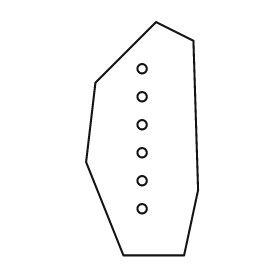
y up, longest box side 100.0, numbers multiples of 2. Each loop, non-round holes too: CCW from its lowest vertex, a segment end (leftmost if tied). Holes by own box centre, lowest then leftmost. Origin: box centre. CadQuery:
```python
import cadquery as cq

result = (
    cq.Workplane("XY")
    .moveTo(-8.0, -50.0)
    .lineTo(18.0, -50.0)
    .lineTo(24.0, -22.0)
    .lineTo(22.0, 42.0)
    .lineTo(6.0, 50.0)
    .lineTo(-20.0, 24.0)
    .lineTo(-24.0, -10.0)
    .close()
    .moveTo(0.0, -30.0)
    .circle(2.0)
    .moveTo(0.0, -18.0)
    .circle(2.0)
    .moveTo(0.0, -6.0)
    .circle(2.0)
    .moveTo(0.0, 6.0)
    .circle(2.0)
    .moveTo(0.0, 18.0)
    .circle(2.0)
    .moveTo(0.0, 30.0)
    .circle(2.0)
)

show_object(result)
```